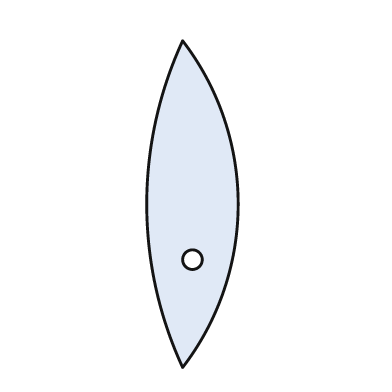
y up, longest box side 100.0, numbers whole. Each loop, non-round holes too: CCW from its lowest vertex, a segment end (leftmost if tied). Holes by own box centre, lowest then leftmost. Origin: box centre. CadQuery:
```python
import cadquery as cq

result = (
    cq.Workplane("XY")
    .moveTo(-3.0, -50.0)
    .threePointArc((14.0, 0.0), (-3.0, 50.0))
    .threePointArc((-14.0, 0.0), (-3.0, -50.0))
    .close()
    .moveTo(0.0, -17.0)
    .circle(3.0)
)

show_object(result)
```